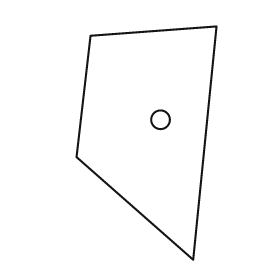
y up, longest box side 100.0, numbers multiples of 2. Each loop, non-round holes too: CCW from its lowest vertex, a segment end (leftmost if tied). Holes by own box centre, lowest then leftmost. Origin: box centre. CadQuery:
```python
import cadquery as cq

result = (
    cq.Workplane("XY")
    .moveTo(20.0, -50.0)
    .lineTo(30.0, 50.0)
    .lineTo(-24.0, 46.0)
    .lineTo(-30.0, -6.0)
    .close()
    .moveTo(6.0, 10.0)
    .circle(4.0)
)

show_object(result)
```